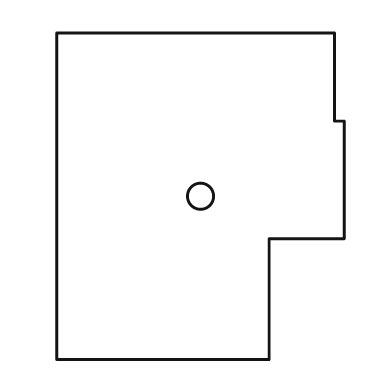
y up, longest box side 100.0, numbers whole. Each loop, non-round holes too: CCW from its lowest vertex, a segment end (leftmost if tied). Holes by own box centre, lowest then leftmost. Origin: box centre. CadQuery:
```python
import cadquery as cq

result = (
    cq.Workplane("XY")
    .moveTo(-44.0, -50.0)
    .lineTo(21.0, -50.0)
    .lineTo(21.0, -13.0)
    .lineTo(44.0, -13.0)
    .lineTo(44.0, 23.0)
    .lineTo(41.0, 23.0)
    .lineTo(41.0, 50.0)
    .lineTo(-44.0, 50.0)
    .close()
    .moveTo(0.0, 0.0)
    .circle(4.0)
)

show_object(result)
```